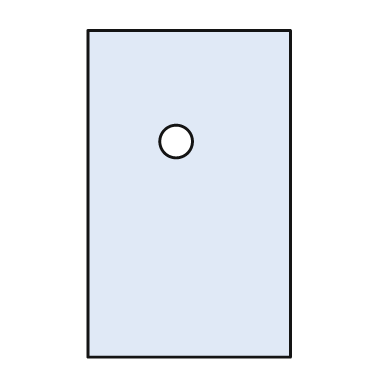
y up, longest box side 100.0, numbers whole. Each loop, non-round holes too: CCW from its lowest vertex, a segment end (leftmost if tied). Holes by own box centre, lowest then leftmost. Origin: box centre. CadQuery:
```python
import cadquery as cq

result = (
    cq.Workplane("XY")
    .moveTo(-31.0, -50.0)
    .lineTo(31.0, -50.0)
    .lineTo(31.0, 50.0)
    .lineTo(-31.0, 50.0)
    .close()
    .moveTo(-4.0, 16.0)
    .circle(5.0)
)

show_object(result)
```